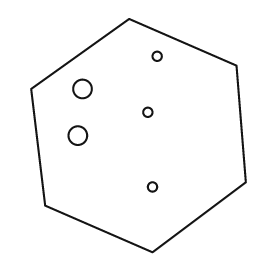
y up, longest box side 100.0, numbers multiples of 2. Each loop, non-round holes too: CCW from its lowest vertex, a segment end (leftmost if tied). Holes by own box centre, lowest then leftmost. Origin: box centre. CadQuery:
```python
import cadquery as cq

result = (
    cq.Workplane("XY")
    .moveTo(6.0, -50.0)
    .lineTo(46.0, -20.0)
    .lineTo(42.0, 30.0)
    .lineTo(-4.0, 50.0)
    .lineTo(-46.0, 20.0)
    .lineTo(-40.0, -30.0)
    .close()
    .moveTo(6.0, -22.0)
    .circle(2.0)
    .moveTo(-26.0, 0.0)
    .circle(4.0)
    .moveTo(4.0, 10.0)
    .circle(2.0)
    .moveTo(-24.0, 20.0)
    .circle(4.0)
    .moveTo(8.0, 34.0)
    .circle(2.0)
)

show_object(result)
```